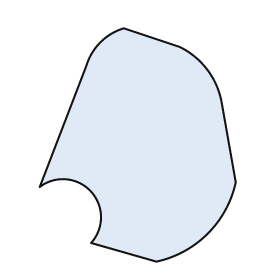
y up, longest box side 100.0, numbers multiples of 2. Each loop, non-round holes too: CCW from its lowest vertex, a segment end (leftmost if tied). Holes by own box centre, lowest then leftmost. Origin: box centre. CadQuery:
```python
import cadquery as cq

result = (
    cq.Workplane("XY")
    .moveTo(8.0, -50.0)
    .threePointArc((30.0, -38.0), (42.0, -16.0))
    .lineTo(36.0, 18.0)
    .threePointArc((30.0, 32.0), (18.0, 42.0))
    .lineTo(-6.0, 50.0)
    .threePointArc((-16.0, 44.0), (-22.0, 34.0))
    .lineTo(-42.0, -18.0)
    .threePointArc((-20.0, -20.0), (-20.0, -42.0))
    .close()
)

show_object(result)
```